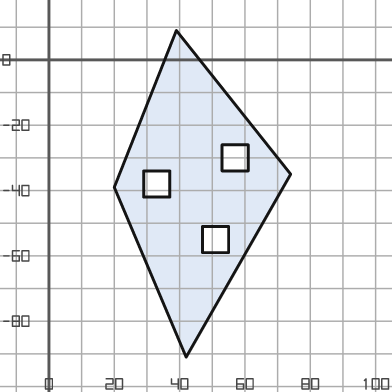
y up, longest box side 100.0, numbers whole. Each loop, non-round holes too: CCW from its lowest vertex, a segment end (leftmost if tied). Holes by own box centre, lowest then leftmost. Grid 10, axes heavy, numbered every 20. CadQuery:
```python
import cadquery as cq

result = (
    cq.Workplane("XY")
    .moveTo(42.0, -91.0)
    .lineTo(74.0, -35.0)
    .lineTo(39.0, 9.0)
    .lineTo(20.0, -39.0)
    .close()
    .moveTo(47.0, -59.0)
    .lineTo(55.0, -59.0)
    .lineTo(55.0, -51.0)
    .lineTo(47.0, -51.0)
    .close()
    .moveTo(29.0, -42.0)
    .lineTo(37.0, -42.0)
    .lineTo(37.0, -34.0)
    .lineTo(29.0, -34.0)
    .close()
    .moveTo(53.0, -34.0)
    .lineTo(61.0, -34.0)
    .lineTo(61.0, -26.0)
    .lineTo(53.0, -26.0)
    .close()
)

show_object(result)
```